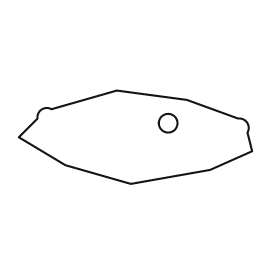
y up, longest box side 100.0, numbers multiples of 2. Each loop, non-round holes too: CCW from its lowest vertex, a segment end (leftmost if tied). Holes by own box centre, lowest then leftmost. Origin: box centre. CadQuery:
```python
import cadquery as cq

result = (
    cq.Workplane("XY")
    .moveTo(-2.0, -20.0)
    .lineTo(32.0, -14.0)
    .lineTo(50.0, -6.0)
    .lineTo(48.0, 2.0)
    .threePointArc((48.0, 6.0), (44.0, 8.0))
    .lineTo(22.0, 16.0)
    .lineTo(-8.0, 20.0)
    .lineTo(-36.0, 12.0)
    .threePointArc((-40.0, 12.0), (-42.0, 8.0))
    .lineTo(-50.0, 0.0)
    .lineTo(-30.0, -12.0)
    .close()
    .moveTo(14.0, 6.0)
    .circle(4.0)
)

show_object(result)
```